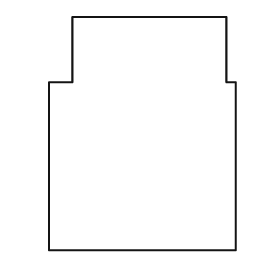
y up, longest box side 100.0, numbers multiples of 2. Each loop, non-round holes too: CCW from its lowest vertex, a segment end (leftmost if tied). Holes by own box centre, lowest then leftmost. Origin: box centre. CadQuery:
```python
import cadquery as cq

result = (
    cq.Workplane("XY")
    .moveTo(-40.0, -50.0)
    .lineTo(40.0, -50.0)
    .lineTo(40.0, 22.0)
    .lineTo(36.0, 22.0)
    .lineTo(36.0, 50.0)
    .lineTo(-30.0, 50.0)
    .lineTo(-30.0, 22.0)
    .lineTo(-40.0, 22.0)
    .close()
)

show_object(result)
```